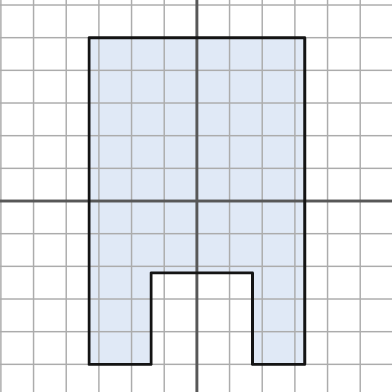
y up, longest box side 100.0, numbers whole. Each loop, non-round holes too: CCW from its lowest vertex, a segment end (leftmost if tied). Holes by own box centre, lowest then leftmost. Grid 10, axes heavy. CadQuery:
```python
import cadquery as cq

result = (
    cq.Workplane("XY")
    .moveTo(-33.0, -50.0)
    .lineTo(-14.0, -50.0)
    .lineTo(-14.0, -22.0)
    .lineTo(17.0, -22.0)
    .lineTo(17.0, -50.0)
    .lineTo(33.0, -50.0)
    .lineTo(33.0, 50.0)
    .lineTo(-33.0, 50.0)
    .close()
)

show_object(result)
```